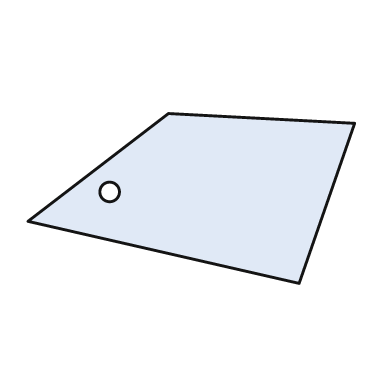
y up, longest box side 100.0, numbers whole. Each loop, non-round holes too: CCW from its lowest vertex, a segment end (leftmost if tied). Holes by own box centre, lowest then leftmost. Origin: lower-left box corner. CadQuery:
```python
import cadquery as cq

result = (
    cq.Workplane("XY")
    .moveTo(83.0, 0.0)
    .lineTo(100.0, 49.0)
    .lineTo(43.0, 52.0)
    .lineTo(0.0, 19.0)
    .close()
    .moveTo(25.0, 28.0)
    .circle(3.0)
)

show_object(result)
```